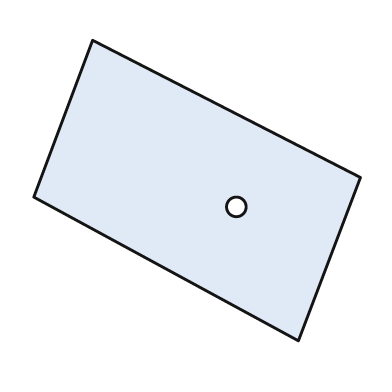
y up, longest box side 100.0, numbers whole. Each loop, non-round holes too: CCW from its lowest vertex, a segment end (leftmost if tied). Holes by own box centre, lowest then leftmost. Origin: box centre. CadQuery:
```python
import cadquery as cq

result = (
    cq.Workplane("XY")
    .moveTo(31.0, -46.0)
    .lineTo(50.0, 4.0)
    .lineTo(-32.0, 46.0)
    .lineTo(-50.0, -2.0)
    .close()
    .moveTo(12.0, -5.0)
    .circle(3.0)
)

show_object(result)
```